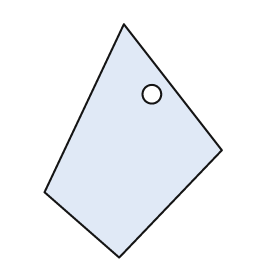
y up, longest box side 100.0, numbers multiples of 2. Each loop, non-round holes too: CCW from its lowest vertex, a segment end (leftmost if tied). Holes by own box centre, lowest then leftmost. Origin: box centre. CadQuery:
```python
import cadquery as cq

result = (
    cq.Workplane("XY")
    .moveTo(-6.0, -50.0)
    .lineTo(38.0, -4.0)
    .lineTo(-4.0, 50.0)
    .lineTo(-38.0, -22.0)
    .close()
    .moveTo(8.0, 20.0)
    .circle(4.0)
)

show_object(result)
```